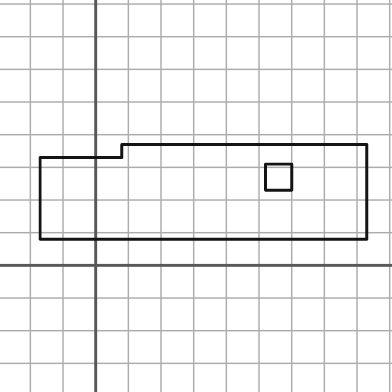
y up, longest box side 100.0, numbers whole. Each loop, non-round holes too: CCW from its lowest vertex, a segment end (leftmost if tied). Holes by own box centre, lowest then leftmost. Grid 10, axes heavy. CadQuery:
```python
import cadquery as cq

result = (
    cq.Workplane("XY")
    .moveTo(-17.0, 8.0)
    .lineTo(83.0, 8.0)
    .lineTo(83.0, 37.0)
    .lineTo(8.0, 37.0)
    .lineTo(8.0, 33.0)
    .lineTo(-17.0, 33.0)
    .close()
    .moveTo(52.0, 23.0)
    .lineTo(60.0, 23.0)
    .lineTo(60.0, 31.0)
    .lineTo(52.0, 31.0)
    .close()
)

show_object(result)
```